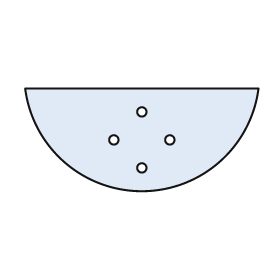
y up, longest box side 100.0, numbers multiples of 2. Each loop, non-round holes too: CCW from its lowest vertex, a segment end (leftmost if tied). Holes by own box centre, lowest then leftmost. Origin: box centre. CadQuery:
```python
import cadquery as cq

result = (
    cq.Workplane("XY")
    .moveTo(-50.0, 22.0)
    .threePointArc((0.0, -22.0), (50.0, 22.0))
    .close()
    .moveTo(0.0, -12.0)
    .circle(2.0)
    .moveTo(-12.0, 0.0)
    .circle(2.0)
    .moveTo(12.0, 0.0)
    .circle(2.0)
    .moveTo(0.0, 12.0)
    .circle(2.0)
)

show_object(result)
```